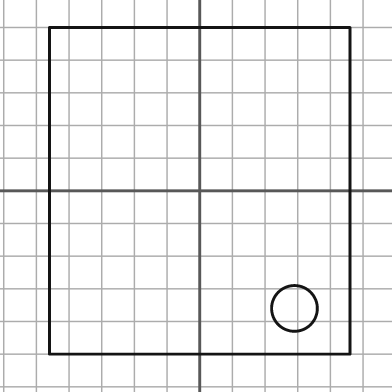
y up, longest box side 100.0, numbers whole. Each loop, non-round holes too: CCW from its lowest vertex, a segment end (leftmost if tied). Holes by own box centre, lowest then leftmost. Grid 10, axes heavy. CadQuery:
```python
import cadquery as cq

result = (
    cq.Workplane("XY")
    .moveTo(-46.0, -50.0)
    .lineTo(46.0, -50.0)
    .lineTo(46.0, 50.0)
    .lineTo(-46.0, 50.0)
    .close()
    .moveTo(29.0, -36.0)
    .circle(7.0)
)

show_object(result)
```